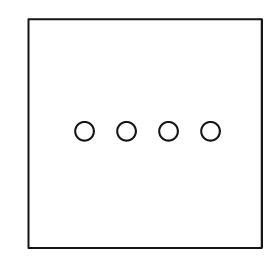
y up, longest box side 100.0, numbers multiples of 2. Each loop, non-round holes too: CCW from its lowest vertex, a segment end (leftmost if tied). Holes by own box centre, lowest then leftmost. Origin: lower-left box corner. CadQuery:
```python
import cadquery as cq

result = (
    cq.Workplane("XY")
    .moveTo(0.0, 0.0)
    .lineTo(100.0, 0.0)
    .lineTo(100.0, 98.0)
    .lineTo(0.0, 98.0)
    .close()
    .moveTo(24.0, 50.0)
    .circle(4.0)
    .moveTo(42.0, 50.0)
    .circle(4.0)
    .moveTo(60.0, 50.0)
    .circle(4.0)
    .moveTo(78.0, 50.0)
    .circle(4.0)
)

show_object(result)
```